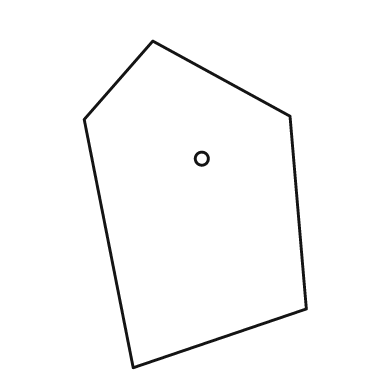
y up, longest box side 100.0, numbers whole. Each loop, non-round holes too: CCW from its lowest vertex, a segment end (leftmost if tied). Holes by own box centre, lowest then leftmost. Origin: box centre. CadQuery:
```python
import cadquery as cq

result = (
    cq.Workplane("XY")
    .moveTo(-19.0, -50.0)
    .lineTo(34.0, -32.0)
    .lineTo(29.0, 27.0)
    .lineTo(-13.0, 50.0)
    .lineTo(-34.0, 26.0)
    .close()
    .moveTo(2.0, 14.0)
    .circle(2.0)
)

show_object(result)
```